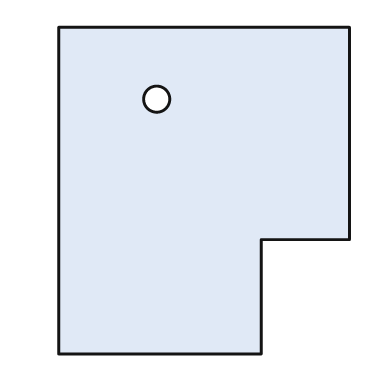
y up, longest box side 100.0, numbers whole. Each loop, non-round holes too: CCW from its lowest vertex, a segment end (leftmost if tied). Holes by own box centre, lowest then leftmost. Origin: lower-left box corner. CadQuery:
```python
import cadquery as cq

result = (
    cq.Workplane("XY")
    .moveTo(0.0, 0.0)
    .lineTo(62.0, 0.0)
    .lineTo(62.0, 35.0)
    .lineTo(89.0, 35.0)
    .lineTo(89.0, 100.0)
    .lineTo(0.0, 100.0)
    .close()
    .moveTo(30.0, 78.0)
    .circle(4.0)
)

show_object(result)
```